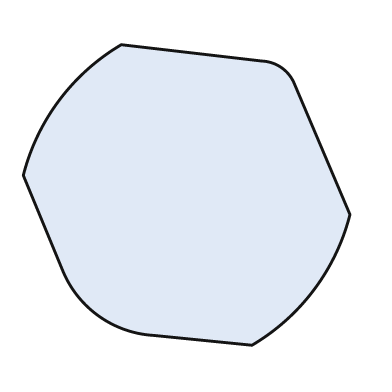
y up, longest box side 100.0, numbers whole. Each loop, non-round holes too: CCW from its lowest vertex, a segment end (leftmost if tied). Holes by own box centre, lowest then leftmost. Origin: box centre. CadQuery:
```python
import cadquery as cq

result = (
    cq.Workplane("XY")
    .moveTo(20.0, -46.0)
    .threePointArc((39.0, -29.0), (50.0, -6.0))
    .lineTo(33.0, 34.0)
    .threePointArc((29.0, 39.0), (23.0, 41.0))
    .lineTo(-20.0, 46.0)
    .threePointArc((-39.0, 29.0), (-50.0, 6.0))
    .lineTo(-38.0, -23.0)
    .threePointArc((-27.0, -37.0), (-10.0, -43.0))
    .close()
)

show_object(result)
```